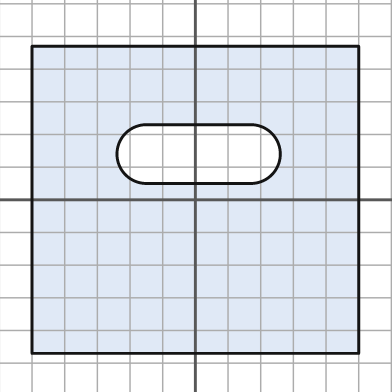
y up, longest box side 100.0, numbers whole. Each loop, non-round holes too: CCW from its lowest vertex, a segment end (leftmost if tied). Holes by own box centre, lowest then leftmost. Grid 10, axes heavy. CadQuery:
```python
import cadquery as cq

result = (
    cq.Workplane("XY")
    .moveTo(-50.0, -47.0)
    .lineTo(50.0, -47.0)
    .lineTo(50.0, 47.0)
    .lineTo(-50.0, 47.0)
    .close()
    .moveTo(-15.0, 5.0)
    .lineTo(17.0, 5.0)
    .threePointArc((26.0, 14.0), (17.0, 23.0))
    .lineTo(-15.0, 23.0)
    .threePointArc((-24.0, 14.0), (-15.0, 5.0))
    .close()
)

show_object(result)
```